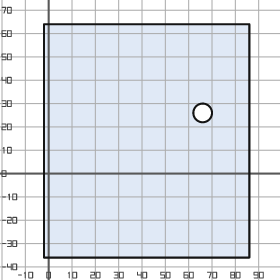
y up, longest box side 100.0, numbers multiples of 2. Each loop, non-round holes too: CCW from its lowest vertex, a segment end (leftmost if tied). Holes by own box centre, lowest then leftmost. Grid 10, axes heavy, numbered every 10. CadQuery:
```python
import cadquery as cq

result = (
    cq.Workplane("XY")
    .moveTo(-2.0, -36.0)
    .lineTo(86.0, -36.0)
    .lineTo(86.0, 64.0)
    .lineTo(-2.0, 64.0)
    .close()
    .moveTo(66.0, 26.0)
    .circle(4.0)
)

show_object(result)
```